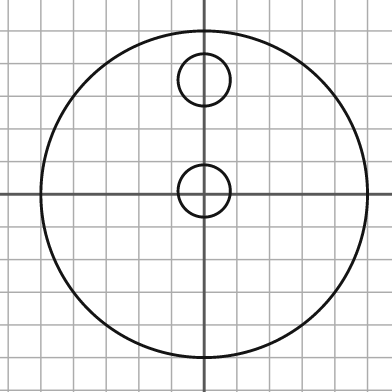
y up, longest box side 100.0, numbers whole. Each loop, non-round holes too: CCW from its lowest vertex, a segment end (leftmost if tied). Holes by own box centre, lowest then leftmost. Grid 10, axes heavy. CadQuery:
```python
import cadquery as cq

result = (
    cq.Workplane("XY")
    .moveTo(0.0, 0.0)
    .circle(50.0)
    .moveTo(0.0, 1.0)
    .circle(8.0)
    .moveTo(0.0, 35.0)
    .circle(8.0)
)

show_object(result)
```